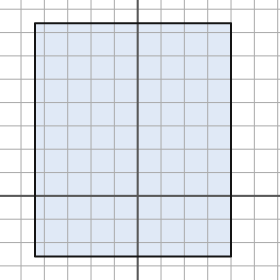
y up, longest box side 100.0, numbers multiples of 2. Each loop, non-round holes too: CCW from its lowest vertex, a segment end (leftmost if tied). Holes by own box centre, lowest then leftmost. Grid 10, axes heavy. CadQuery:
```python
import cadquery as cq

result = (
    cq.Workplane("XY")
    .moveTo(-44.0, -26.0)
    .lineTo(40.0, -26.0)
    .lineTo(40.0, 74.0)
    .lineTo(-44.0, 74.0)
    .close()
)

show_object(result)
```